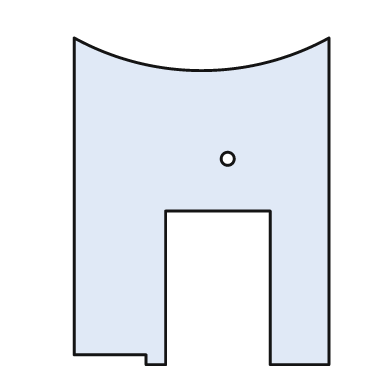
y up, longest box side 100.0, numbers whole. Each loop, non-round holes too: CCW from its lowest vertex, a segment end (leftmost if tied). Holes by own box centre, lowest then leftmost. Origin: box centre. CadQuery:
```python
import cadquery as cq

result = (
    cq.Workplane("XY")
    .moveTo(-17.0, -50.0)
    .lineTo(-11.0, -50.0)
    .lineTo(-11.0, -3.0)
    .lineTo(21.0, -3.0)
    .lineTo(21.0, -50.0)
    .lineTo(39.0, -50.0)
    .lineTo(39.0, 50.0)
    .threePointArc((0.0, 40.0), (-39.0, 50.0))
    .lineTo(-39.0, -47.0)
    .lineTo(-17.0, -47.0)
    .close()
    .moveTo(8.0, 13.0)
    .circle(2.0)
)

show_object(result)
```